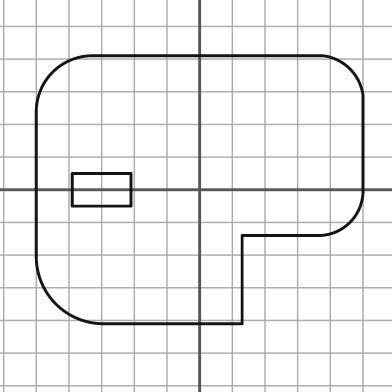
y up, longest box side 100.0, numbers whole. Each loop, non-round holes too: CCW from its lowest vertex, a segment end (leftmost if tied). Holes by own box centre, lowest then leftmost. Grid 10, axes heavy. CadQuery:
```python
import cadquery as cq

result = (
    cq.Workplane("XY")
    .moveTo(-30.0, -41.0)
    .lineTo(13.0, -41.0)
    .lineTo(13.0, -14.0)
    .lineTo(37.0, -14.0)
    .threePointArc((46.0, -10.0), (50.0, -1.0))
    .lineTo(50.0, 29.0)
    .threePointArc((46.0, 37.0), (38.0, 41.0))
    .lineTo(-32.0, 41.0)
    .threePointArc((-45.0, 36.0), (-50.0, 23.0))
    .lineTo(-50.0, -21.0)
    .threePointArc((-44.0, -35.0), (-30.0, -41.0))
    .close()
    .moveTo(-39.0, -5.0)
    .lineTo(-21.0, -5.0)
    .lineTo(-21.0, 5.0)
    .lineTo(-39.0, 5.0)
    .close()
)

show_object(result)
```